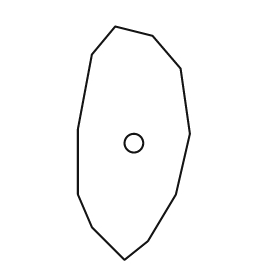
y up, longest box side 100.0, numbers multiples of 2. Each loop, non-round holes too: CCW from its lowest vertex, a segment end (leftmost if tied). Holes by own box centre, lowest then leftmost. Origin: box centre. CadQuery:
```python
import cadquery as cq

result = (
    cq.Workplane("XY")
    .moveTo(-4.0, -50.0)
    .lineTo(6.0, -42.0)
    .lineTo(18.0, -22.0)
    .lineTo(24.0, 4.0)
    .lineTo(20.0, 32.0)
    .lineTo(8.0, 46.0)
    .lineTo(-8.0, 50.0)
    .lineTo(-18.0, 38.0)
    .lineTo(-24.0, 6.0)
    .lineTo(-24.0, -22.0)
    .lineTo(-18.0, -36.0)
    .close()
    .moveTo(0.0, 0.0)
    .circle(4.0)
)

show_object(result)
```